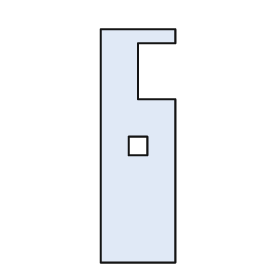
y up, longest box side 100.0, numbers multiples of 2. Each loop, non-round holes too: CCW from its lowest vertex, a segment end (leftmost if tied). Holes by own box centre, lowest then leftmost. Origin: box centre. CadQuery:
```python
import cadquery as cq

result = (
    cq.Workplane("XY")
    .moveTo(-16.0, -50.0)
    .lineTo(16.0, -50.0)
    .lineTo(16.0, 20.0)
    .lineTo(0.0, 20.0)
    .lineTo(0.0, 44.0)
    .lineTo(16.0, 44.0)
    .lineTo(16.0, 50.0)
    .lineTo(-16.0, 50.0)
    .close()
    .moveTo(-4.0, -4.0)
    .lineTo(4.0, -4.0)
    .lineTo(4.0, 4.0)
    .lineTo(-4.0, 4.0)
    .close()
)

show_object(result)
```